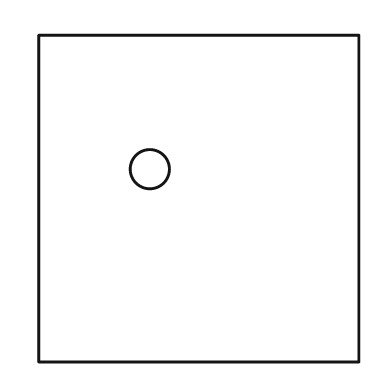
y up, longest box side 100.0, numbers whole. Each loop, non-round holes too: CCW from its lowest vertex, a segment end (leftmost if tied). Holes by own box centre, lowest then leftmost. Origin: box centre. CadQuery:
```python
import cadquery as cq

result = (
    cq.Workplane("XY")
    .moveTo(-49.0, -50.0)
    .lineTo(49.0, -50.0)
    .lineTo(49.0, 50.0)
    .lineTo(-49.0, 50.0)
    .close()
    .moveTo(-15.0, 9.0)
    .circle(6.0)
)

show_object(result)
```